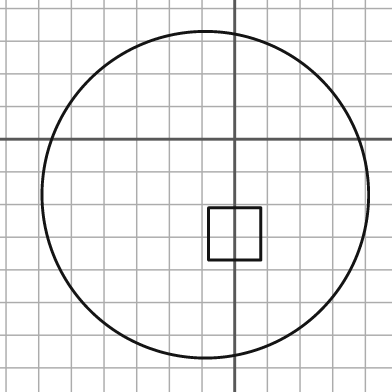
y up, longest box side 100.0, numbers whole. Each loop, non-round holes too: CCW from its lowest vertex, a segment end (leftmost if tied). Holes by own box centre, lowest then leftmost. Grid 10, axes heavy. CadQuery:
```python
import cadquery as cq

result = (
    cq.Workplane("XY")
    .moveTo(-9.0, -17.0)
    .circle(50.0)
    .moveTo(-8.0, -37.0)
    .lineTo(8.0, -37.0)
    .lineTo(8.0, -21.0)
    .lineTo(-8.0, -21.0)
    .close()
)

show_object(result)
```